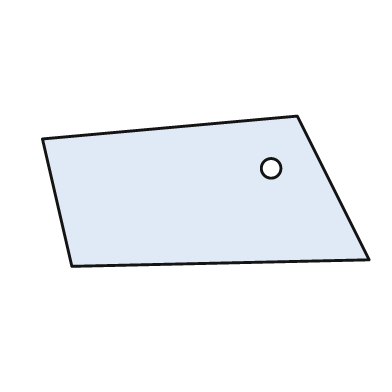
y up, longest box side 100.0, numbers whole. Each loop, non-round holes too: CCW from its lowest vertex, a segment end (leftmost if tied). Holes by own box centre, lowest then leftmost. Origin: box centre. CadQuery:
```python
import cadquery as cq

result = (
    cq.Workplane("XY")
    .moveTo(-41.0, -23.0)
    .lineTo(50.0, -21.0)
    .lineTo(28.0, 23.0)
    .lineTo(-50.0, 16.0)
    .close()
    .moveTo(20.0, 7.0)
    .circle(3.0)
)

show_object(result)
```